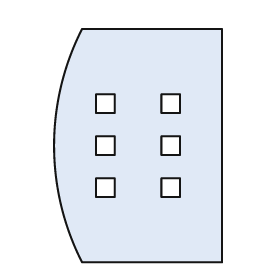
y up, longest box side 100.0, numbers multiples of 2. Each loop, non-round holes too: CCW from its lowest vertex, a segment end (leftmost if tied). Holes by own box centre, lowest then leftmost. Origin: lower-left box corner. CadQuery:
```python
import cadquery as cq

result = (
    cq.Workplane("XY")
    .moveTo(12.0, 0.0)
    .lineTo(72.0, 0.0)
    .lineTo(72.0, 100.0)
    .lineTo(12.0, 100.0)
    .threePointArc((0.0, 50.0), (12.0, 0.0))
    .close()
    .moveTo(18.0, 28.0)
    .lineTo(26.0, 28.0)
    .lineTo(26.0, 36.0)
    .lineTo(18.0, 36.0)
    .close()
    .moveTo(46.0, 28.0)
    .lineTo(54.0, 28.0)
    .lineTo(54.0, 36.0)
    .lineTo(46.0, 36.0)
    .close()
    .moveTo(18.0, 46.0)
    .lineTo(26.0, 46.0)
    .lineTo(26.0, 54.0)
    .lineTo(18.0, 54.0)
    .close()
    .moveTo(46.0, 46.0)
    .lineTo(54.0, 46.0)
    .lineTo(54.0, 54.0)
    .lineTo(46.0, 54.0)
    .close()
    .moveTo(18.0, 64.0)
    .lineTo(26.0, 64.0)
    .lineTo(26.0, 72.0)
    .lineTo(18.0, 72.0)
    .close()
    .moveTo(46.0, 64.0)
    .lineTo(54.0, 64.0)
    .lineTo(54.0, 72.0)
    .lineTo(46.0, 72.0)
    .close()
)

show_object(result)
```